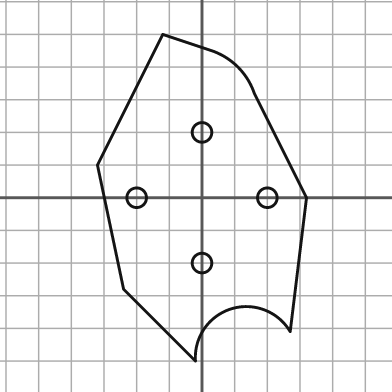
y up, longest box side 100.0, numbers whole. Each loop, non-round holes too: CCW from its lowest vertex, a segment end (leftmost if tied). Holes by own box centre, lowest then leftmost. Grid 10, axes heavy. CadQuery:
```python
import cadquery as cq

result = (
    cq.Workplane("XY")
    .moveTo(-2.0, -50.0)
    .threePointArc((9.0, -34.0), (27.0, -41.0))
    .lineTo(32.0, 0.0)
    .lineTo(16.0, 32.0)
    .threePointArc((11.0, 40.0), (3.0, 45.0))
    .lineTo(-12.0, 50.0)
    .lineTo(-32.0, 10.0)
    .lineTo(-24.0, -28.0)
    .close()
    .moveTo(0.0, -20.0)
    .circle(3.0)
    .moveTo(-20.0, 0.0)
    .circle(3.0)
    .moveTo(20.0, 0.0)
    .circle(3.0)
    .moveTo(0.0, 20.0)
    .circle(3.0)
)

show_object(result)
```